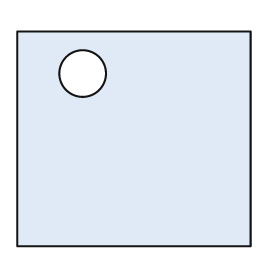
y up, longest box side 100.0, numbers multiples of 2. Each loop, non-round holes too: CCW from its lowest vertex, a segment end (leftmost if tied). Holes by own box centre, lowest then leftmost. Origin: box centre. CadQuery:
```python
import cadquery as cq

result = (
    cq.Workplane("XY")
    .moveTo(-50.0, -46.0)
    .lineTo(50.0, -46.0)
    .lineTo(50.0, 46.0)
    .lineTo(-50.0, 46.0)
    .close()
    .moveTo(-22.0, 28.0)
    .circle(10.0)
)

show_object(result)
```